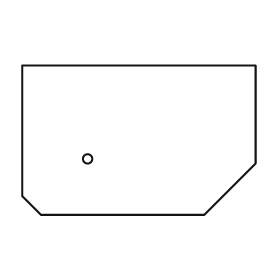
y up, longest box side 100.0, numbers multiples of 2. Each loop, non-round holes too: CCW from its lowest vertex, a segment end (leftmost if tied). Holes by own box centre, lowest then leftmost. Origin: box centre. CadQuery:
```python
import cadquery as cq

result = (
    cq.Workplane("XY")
    .moveTo(-42.0, -32.0)
    .lineTo(28.0, -32.0)
    .lineTo(50.0, -10.0)
    .lineTo(50.0, 32.0)
    .lineTo(-50.0, 32.0)
    .lineTo(-50.0, -24.0)
    .close()
    .moveTo(-22.0, -8.0)
    .circle(2.0)
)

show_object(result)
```